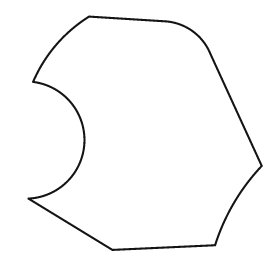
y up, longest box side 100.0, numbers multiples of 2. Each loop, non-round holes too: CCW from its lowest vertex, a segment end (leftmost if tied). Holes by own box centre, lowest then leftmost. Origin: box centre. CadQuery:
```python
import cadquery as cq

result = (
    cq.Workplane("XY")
    .moveTo(-14.0, -50.0)
    .lineTo(30.0, -48.0)
    .threePointArc((38.0, -30.0), (50.0, -14.0))
    .lineTo(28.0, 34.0)
    .threePointArc((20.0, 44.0), (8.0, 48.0))
    .lineTo(-24.0, 50.0)
    .threePointArc((-38.0, 38.0), (-48.0, 22.0))
    .threePointArc((-26.0, -4.0), (-50.0, -28.0))
    .close()
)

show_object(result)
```